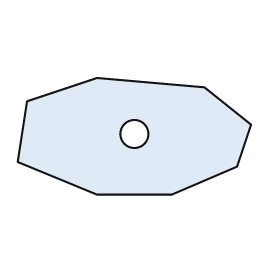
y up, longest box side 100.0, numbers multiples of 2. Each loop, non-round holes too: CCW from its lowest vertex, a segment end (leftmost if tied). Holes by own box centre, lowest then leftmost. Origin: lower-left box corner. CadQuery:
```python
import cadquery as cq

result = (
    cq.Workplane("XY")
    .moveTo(34.0, 0.0)
    .lineTo(66.0, 0.0)
    .lineTo(94.0, 12.0)
    .lineTo(100.0, 30.0)
    .lineTo(80.0, 46.0)
    .lineTo(34.0, 50.0)
    .lineTo(4.0, 40.0)
    .lineTo(0.0, 14.0)
    .close()
    .moveTo(50.0, 26.0)
    .circle(6.0)
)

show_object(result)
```